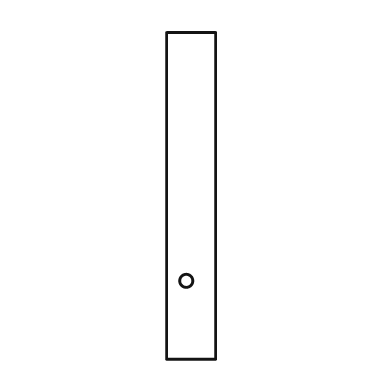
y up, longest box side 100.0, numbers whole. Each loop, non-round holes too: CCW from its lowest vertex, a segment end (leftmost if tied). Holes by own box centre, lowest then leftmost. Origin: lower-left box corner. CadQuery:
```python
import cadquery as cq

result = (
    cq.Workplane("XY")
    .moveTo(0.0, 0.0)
    .lineTo(15.0, 0.0)
    .lineTo(15.0, 100.0)
    .lineTo(0.0, 100.0)
    .close()
    .moveTo(6.0, 24.0)
    .circle(2.0)
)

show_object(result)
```